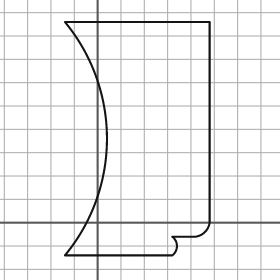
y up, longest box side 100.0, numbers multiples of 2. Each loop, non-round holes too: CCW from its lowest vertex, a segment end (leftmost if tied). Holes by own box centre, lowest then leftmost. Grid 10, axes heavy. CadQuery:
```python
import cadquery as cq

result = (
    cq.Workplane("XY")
    .moveTo(-14.0, -14.0)
    .lineTo(32.0, -14.0)
    .threePointArc((34.0, -10.0), (32.0, -6.0))
    .lineTo(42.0, -6.0)
    .threePointArc((46.0, -4.0), (48.0, 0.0))
    .lineTo(48.0, 86.0)
    .lineTo(-14.0, 86.0)
    .threePointArc((4.0, 36.0), (-14.0, -14.0))
    .close()
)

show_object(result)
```